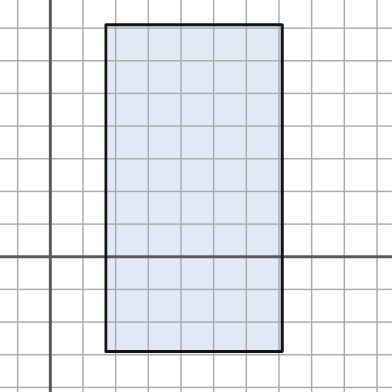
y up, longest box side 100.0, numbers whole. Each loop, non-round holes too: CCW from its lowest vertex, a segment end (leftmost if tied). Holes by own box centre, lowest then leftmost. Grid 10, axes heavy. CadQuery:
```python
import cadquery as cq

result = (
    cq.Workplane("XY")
    .moveTo(17.0, -29.0)
    .lineTo(71.0, -29.0)
    .lineTo(71.0, 71.0)
    .lineTo(17.0, 71.0)
    .close()
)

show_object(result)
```